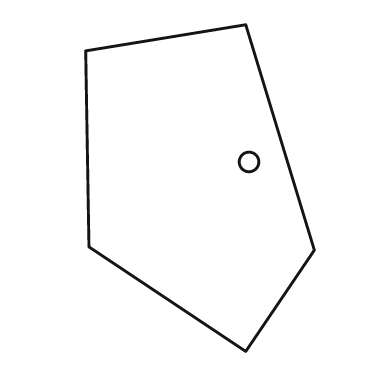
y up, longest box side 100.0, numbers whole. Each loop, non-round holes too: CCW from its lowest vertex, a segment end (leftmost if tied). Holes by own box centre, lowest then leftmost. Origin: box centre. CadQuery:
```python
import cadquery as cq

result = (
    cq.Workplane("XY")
    .moveTo(14.0, -50.0)
    .lineTo(35.0, -19.0)
    .lineTo(14.0, 50.0)
    .lineTo(-35.0, 42.0)
    .lineTo(-34.0, -18.0)
    .close()
    .moveTo(15.0, 8.0)
    .circle(3.0)
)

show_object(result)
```